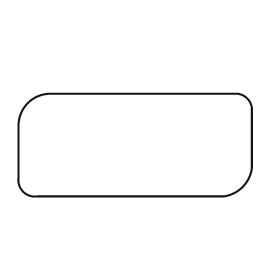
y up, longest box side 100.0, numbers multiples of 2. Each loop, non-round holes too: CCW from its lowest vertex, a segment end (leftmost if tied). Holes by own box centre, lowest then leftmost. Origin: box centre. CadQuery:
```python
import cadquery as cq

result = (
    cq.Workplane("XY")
    .moveTo(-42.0, -22.0)
    .lineTo(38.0, -22.0)
    .threePointArc((46.0, -18.0), (50.0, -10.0))
    .lineTo(50.0, 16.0)
    .threePointArc((48.0, 20.0), (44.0, 22.0))
    .lineTo(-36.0, 22.0)
    .threePointArc((-46.0, 18.0), (-50.0, 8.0))
    .lineTo(-50.0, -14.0)
    .threePointArc((-48.0, -20.0), (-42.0, -22.0))
    .close()
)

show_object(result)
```